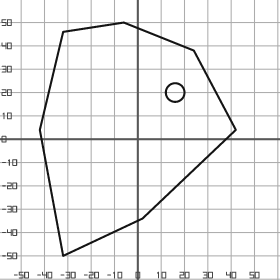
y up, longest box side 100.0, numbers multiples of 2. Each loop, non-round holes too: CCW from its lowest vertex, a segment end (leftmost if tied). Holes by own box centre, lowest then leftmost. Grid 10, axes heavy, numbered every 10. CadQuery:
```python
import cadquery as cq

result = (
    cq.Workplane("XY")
    .moveTo(-32.0, -50.0)
    .lineTo(2.0, -34.0)
    .lineTo(42.0, 4.0)
    .lineTo(24.0, 38.0)
    .lineTo(-6.0, 50.0)
    .lineTo(-32.0, 46.0)
    .lineTo(-42.0, 4.0)
    .close()
    .moveTo(16.0, 20.0)
    .circle(4.0)
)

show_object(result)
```